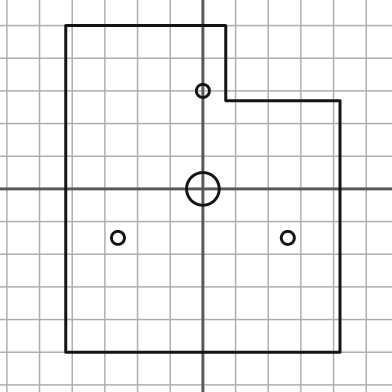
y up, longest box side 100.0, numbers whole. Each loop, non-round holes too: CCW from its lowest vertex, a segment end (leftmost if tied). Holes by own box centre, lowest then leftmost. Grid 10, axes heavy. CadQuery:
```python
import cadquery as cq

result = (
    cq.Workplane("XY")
    .moveTo(-42.0, -50.0)
    .lineTo(42.0, -50.0)
    .lineTo(42.0, 27.0)
    .lineTo(7.0, 27.0)
    .lineTo(7.0, 50.0)
    .lineTo(-42.0, 50.0)
    .close()
    .moveTo(-26.0, -15.0)
    .circle(2.0)
    .moveTo(26.0, -15.0)
    .circle(2.0)
    .moveTo(0.0, 0.0)
    .circle(5.0)
    .moveTo(0.0, 30.0)
    .circle(2.0)
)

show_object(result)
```